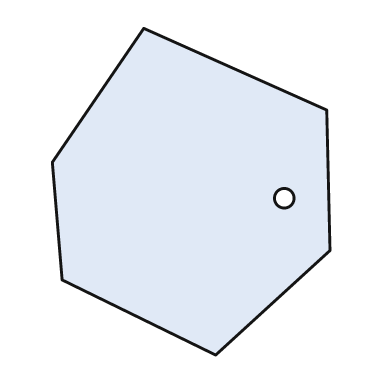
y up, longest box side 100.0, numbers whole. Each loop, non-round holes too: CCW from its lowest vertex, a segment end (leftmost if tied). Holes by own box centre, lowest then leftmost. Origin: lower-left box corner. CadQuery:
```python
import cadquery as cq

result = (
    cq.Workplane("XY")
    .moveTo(50.0, 0.0)
    .lineTo(85.0, 32.0)
    .lineTo(84.0, 75.0)
    .lineTo(28.0, 100.0)
    .lineTo(0.0, 59.0)
    .lineTo(3.0, 23.0)
    .close()
    .moveTo(71.0, 48.0)
    .circle(3.0)
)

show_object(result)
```